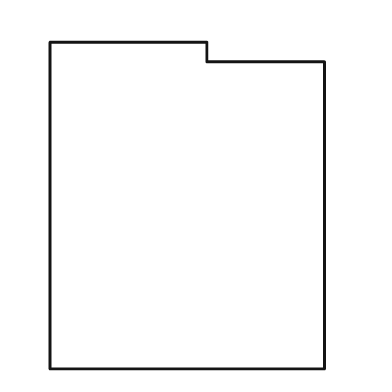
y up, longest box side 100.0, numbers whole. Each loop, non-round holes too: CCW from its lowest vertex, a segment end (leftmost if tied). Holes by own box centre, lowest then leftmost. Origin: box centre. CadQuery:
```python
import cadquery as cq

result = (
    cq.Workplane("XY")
    .moveTo(-42.0, -50.0)
    .lineTo(42.0, -50.0)
    .lineTo(42.0, 44.0)
    .lineTo(6.0, 44.0)
    .lineTo(6.0, 50.0)
    .lineTo(-42.0, 50.0)
    .close()
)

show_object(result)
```